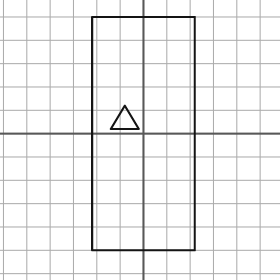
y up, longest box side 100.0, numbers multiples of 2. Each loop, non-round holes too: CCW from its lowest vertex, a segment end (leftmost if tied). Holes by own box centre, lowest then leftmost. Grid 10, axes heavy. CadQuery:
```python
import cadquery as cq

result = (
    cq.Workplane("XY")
    .moveTo(-22.0, -50.0)
    .lineTo(22.0, -50.0)
    .lineTo(22.0, 50.0)
    .lineTo(-22.0, 50.0)
    .close()
    .moveTo(-14.0, 2.0)
    .lineTo(-2.0, 2.0)
    .lineTo(-8.0, 12.0)
    .close()
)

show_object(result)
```